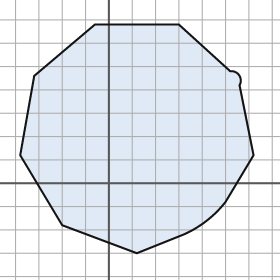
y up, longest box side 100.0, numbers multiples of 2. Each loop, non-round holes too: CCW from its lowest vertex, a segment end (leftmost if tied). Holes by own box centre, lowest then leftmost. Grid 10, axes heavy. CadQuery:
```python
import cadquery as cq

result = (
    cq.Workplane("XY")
    .moveTo(12.0, -30.0)
    .lineTo(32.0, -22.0)
    .threePointArc((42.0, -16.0), (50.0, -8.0))
    .lineTo(62.0, 12.0)
    .lineTo(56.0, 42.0)
    .threePointArc((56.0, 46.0), (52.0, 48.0))
    .lineTo(30.0, 68.0)
    .lineTo(-6.0, 68.0)
    .lineTo(-32.0, 46.0)
    .lineTo(-38.0, 12.0)
    .lineTo(-20.0, -18.0)
    .close()
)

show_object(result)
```